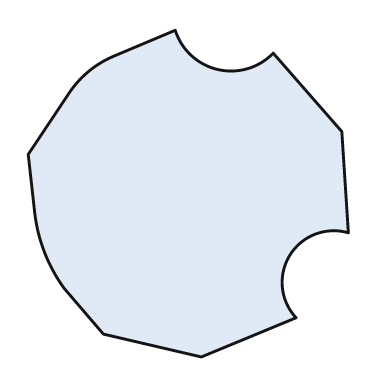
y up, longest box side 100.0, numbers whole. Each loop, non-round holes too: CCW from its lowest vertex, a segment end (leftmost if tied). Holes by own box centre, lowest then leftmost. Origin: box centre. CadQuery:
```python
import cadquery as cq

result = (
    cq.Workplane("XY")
    .moveTo(4.0, -50.0)
    .lineTo(33.0, -38.0)
    .threePointArc((31.0, -19.0), (49.0, -12.0))
    .lineTo(47.0, 19.0)
    .lineTo(26.0, 43.0)
    .threePointArc((9.0, 38.0), (-4.0, 50.0))
    .lineTo(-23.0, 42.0)
    .threePointArc((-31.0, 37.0), (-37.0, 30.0))
    .lineTo(-49.0, 12.0)
    .lineTo(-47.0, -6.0)
    .threePointArc((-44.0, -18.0), (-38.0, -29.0))
    .lineTo(-26.0, -43.0)
    .close()
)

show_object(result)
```